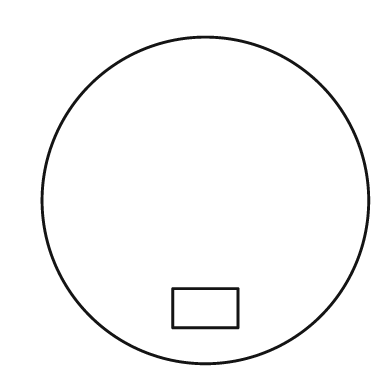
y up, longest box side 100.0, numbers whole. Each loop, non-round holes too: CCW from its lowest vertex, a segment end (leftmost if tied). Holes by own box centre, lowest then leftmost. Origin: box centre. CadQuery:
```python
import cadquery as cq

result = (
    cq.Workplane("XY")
    .moveTo(0.0, 0.0)
    .circle(50.0)
    .moveTo(-10.0, -39.0)
    .lineTo(10.0, -39.0)
    .lineTo(10.0, -27.0)
    .lineTo(-10.0, -27.0)
    .close()
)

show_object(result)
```